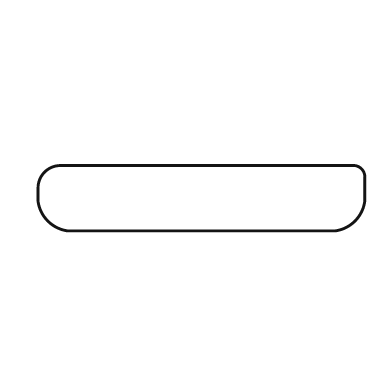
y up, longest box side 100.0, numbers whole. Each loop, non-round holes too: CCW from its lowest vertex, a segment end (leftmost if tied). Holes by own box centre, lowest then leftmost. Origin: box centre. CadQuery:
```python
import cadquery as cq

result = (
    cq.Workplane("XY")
    .moveTo(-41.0, -10.0)
    .lineTo(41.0, -10.0)
    .threePointArc((47.0, -7.0), (50.0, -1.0))
    .lineTo(50.0, 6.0)
    .threePointArc((49.0, 9.0), (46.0, 10.0))
    .lineTo(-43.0, 10.0)
    .threePointArc((-48.0, 8.0), (-50.0, 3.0))
    .lineTo(-50.0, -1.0)
    .threePointArc((-47.0, -7.0), (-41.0, -10.0))
    .close()
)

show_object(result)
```